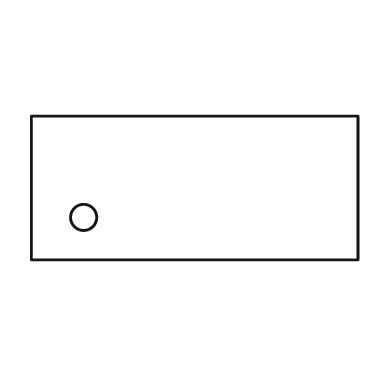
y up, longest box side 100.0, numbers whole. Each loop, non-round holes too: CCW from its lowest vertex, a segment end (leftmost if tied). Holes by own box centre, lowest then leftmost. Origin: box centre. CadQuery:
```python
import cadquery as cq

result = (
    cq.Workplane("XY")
    .moveTo(-50.0, -22.0)
    .lineTo(50.0, -22.0)
    .lineTo(50.0, 22.0)
    .lineTo(-50.0, 22.0)
    .close()
    .moveTo(-34.0, -9.0)
    .circle(4.0)
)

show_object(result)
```